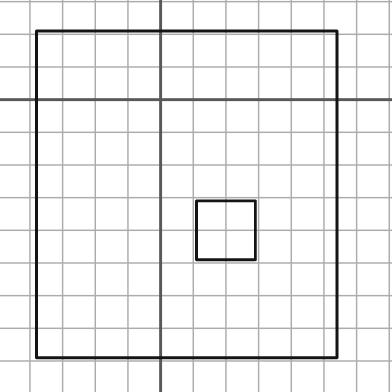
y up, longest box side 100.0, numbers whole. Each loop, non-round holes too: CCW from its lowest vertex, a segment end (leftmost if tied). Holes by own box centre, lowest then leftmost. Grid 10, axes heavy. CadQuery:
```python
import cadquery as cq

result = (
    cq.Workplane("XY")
    .moveTo(-38.0, -79.0)
    .lineTo(54.0, -79.0)
    .lineTo(54.0, 21.0)
    .lineTo(-38.0, 21.0)
    .close()
    .moveTo(11.0, -49.0)
    .lineTo(29.0, -49.0)
    .lineTo(29.0, -31.0)
    .lineTo(11.0, -31.0)
    .close()
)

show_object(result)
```